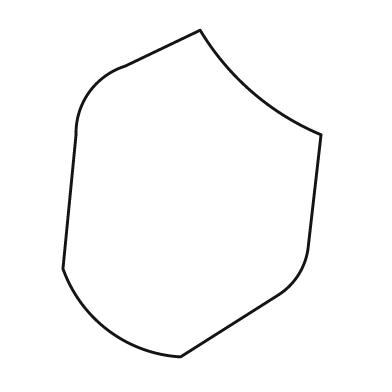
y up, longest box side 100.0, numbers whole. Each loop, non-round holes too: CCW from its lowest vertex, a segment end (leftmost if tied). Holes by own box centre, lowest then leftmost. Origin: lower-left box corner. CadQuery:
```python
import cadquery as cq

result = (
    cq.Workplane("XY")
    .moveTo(36.0, 0.0)
    .lineTo(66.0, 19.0)
    .threePointArc((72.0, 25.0), (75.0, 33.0))
    .lineTo(79.0, 68.0)
    .threePointArc((58.0, 81.0), (42.0, 100.0))
    .lineTo(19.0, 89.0)
    .threePointArc((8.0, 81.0), (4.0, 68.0))
    .lineTo(0.0, 27.0)
    .threePointArc((14.0, 8.0), (36.0, 0.0))
    .close()
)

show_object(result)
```